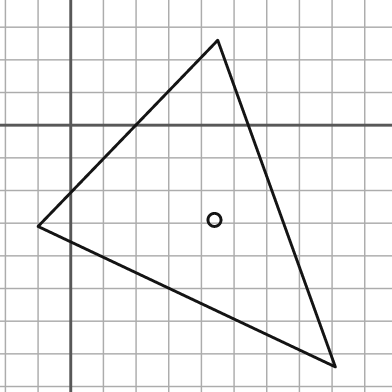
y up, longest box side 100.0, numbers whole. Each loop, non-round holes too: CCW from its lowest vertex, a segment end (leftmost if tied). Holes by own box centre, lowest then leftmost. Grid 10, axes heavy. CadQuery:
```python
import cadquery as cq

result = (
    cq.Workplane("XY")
    .moveTo(81.0, -74.0)
    .lineTo(45.0, 26.0)
    .lineTo(-10.0, -31.0)
    .close()
    .moveTo(44.0, -29.0)
    .circle(2.0)
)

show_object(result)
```